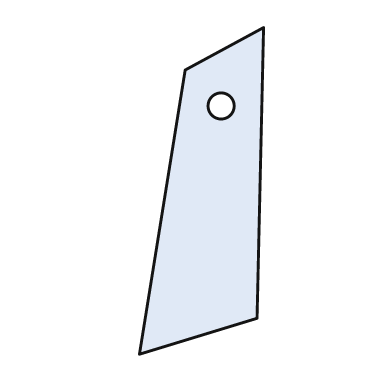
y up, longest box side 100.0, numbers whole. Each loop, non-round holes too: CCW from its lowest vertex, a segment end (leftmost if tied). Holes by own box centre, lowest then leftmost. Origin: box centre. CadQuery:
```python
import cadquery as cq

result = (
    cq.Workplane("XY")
    .moveTo(-19.0, -50.0)
    .lineTo(17.0, -39.0)
    .lineTo(19.0, 50.0)
    .lineTo(-5.0, 37.0)
    .close()
    .moveTo(6.0, 26.0)
    .circle(4.0)
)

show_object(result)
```